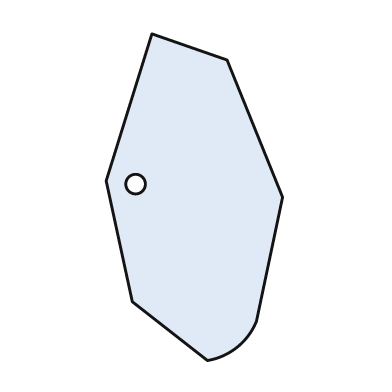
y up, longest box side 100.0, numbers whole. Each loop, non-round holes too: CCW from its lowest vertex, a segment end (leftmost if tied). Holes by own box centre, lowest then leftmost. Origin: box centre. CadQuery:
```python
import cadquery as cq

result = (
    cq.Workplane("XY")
    .moveTo(4.0, -50.0)
    .threePointArc((13.0, -46.0), (19.0, -38.0))
    .lineTo(27.0, 0.0)
    .lineTo(10.0, 42.0)
    .lineTo(-13.0, 50.0)
    .lineTo(-27.0, 5.0)
    .lineTo(-19.0, -32.0)
    .close()
    .moveTo(-18.0, 4.0)
    .circle(3.0)
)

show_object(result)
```